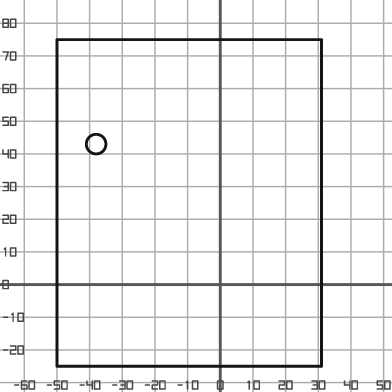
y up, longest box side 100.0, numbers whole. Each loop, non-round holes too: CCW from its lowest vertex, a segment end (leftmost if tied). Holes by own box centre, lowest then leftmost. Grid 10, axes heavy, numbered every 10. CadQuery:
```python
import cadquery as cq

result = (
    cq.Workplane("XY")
    .moveTo(-50.0, -25.0)
    .lineTo(31.0, -25.0)
    .lineTo(31.0, 75.0)
    .lineTo(-50.0, 75.0)
    .close()
    .moveTo(-38.0, 43.0)
    .circle(3.0)
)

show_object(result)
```